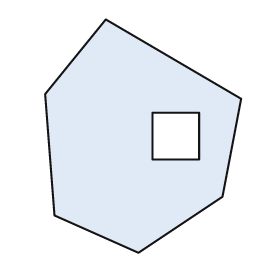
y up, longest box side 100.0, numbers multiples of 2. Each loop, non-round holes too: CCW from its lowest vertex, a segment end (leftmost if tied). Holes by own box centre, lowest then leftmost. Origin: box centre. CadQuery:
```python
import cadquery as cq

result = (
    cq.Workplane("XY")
    .moveTo(-2.0, -50.0)
    .lineTo(34.0, -26.0)
    .lineTo(42.0, 16.0)
    .lineTo(-16.0, 50.0)
    .lineTo(-42.0, 18.0)
    .lineTo(-38.0, -34.0)
    .close()
    .moveTo(4.0, -10.0)
    .lineTo(24.0, -10.0)
    .lineTo(24.0, 10.0)
    .lineTo(4.0, 10.0)
    .close()
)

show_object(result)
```